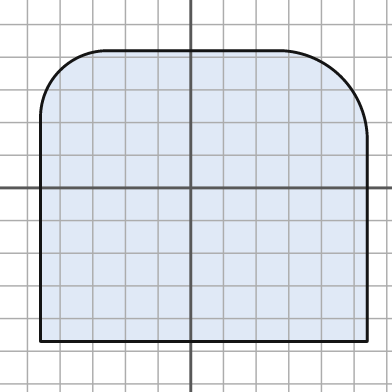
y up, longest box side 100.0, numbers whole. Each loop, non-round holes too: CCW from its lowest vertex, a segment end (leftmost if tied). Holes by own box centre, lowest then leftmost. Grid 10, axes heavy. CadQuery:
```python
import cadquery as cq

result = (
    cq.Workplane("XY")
    .moveTo(-46.0, -47.0)
    .lineTo(54.0, -47.0)
    .lineTo(54.0, 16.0)
    .threePointArc((46.0, 34.0), (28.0, 42.0))
    .lineTo(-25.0, 42.0)
    .threePointArc((-40.0, 36.0), (-46.0, 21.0))
    .close()
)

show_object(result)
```